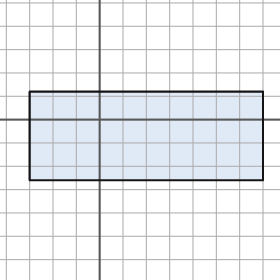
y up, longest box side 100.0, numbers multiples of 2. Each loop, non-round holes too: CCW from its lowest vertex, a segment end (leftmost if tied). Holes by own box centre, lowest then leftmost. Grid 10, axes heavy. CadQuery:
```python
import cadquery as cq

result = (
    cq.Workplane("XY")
    .moveTo(-30.0, -26.0)
    .lineTo(70.0, -26.0)
    .lineTo(70.0, 12.0)
    .lineTo(-30.0, 12.0)
    .close()
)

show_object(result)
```